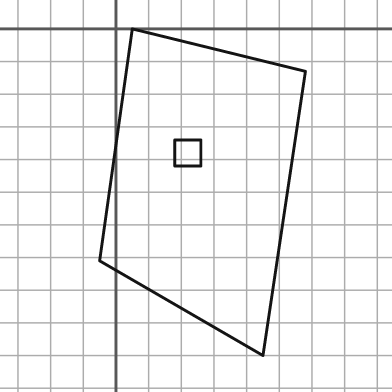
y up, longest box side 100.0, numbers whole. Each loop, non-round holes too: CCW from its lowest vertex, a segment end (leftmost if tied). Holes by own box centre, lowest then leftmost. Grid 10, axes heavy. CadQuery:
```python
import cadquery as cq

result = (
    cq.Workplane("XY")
    .moveTo(45.0, -100.0)
    .lineTo(58.0, -13.0)
    .lineTo(5.0, 0.0)
    .lineTo(-5.0, -71.0)
    .close()
    .moveTo(18.0, -42.0)
    .lineTo(26.0, -42.0)
    .lineTo(26.0, -34.0)
    .lineTo(18.0, -34.0)
    .close()
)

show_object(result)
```